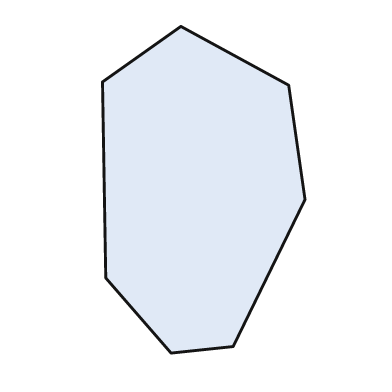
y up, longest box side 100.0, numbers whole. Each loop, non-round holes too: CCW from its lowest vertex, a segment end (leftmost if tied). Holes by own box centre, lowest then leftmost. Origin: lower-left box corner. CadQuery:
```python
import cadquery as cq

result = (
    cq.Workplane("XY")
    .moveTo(21.0, 0.0)
    .lineTo(40.0, 2.0)
    .lineTo(62.0, 47.0)
    .lineTo(57.0, 82.0)
    .lineTo(24.0, 100.0)
    .lineTo(0.0, 83.0)
    .lineTo(1.0, 23.0)
    .close()
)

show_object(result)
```